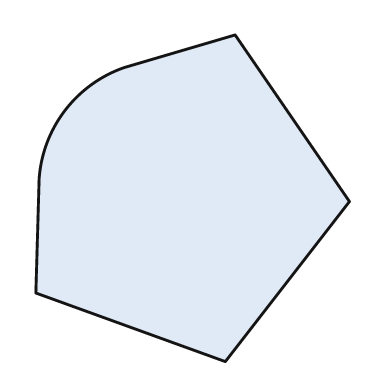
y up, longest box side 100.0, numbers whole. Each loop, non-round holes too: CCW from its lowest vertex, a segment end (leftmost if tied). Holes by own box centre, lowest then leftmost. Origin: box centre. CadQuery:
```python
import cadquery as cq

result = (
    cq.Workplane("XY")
    .moveTo(10.0, -50.0)
    .lineTo(48.0, -1.0)
    .lineTo(13.0, 50.0)
    .lineTo(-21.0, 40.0)
    .threePointArc((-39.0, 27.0), (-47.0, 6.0))
    .lineTo(-48.0, -29.0)
    .close()
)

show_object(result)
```